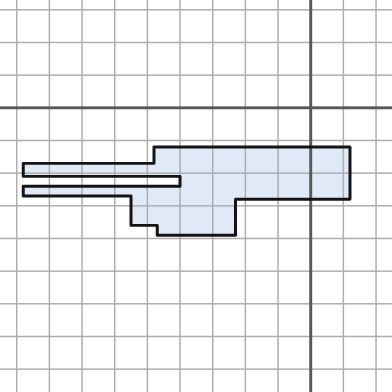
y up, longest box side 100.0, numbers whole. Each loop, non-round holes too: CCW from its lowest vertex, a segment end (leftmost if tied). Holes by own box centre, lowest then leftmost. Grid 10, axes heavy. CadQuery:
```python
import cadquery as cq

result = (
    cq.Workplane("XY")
    .moveTo(-47.0, -39.0)
    .lineTo(-23.0, -39.0)
    .lineTo(-23.0, -28.0)
    .lineTo(12.0, -28.0)
    .lineTo(12.0, -12.0)
    .lineTo(-48.0, -12.0)
    .lineTo(-48.0, -17.0)
    .lineTo(-88.0, -17.0)
    .lineTo(-88.0, -21.0)
    .lineTo(-40.0, -21.0)
    .lineTo(-40.0, -24.0)
    .lineTo(-88.0, -24.0)
    .lineTo(-88.0, -27.0)
    .lineTo(-55.0, -27.0)
    .lineTo(-55.0, -36.0)
    .lineTo(-47.0, -36.0)
    .close()
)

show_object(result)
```